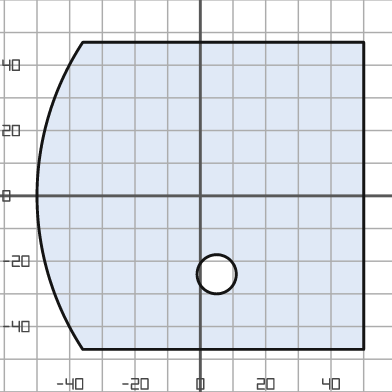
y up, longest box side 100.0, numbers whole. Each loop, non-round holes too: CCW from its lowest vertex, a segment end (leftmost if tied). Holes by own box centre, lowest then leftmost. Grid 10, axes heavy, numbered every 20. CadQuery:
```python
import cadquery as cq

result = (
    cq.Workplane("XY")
    .moveTo(-36.0, -47.0)
    .lineTo(50.0, -47.0)
    .lineTo(50.0, 47.0)
    .lineTo(-36.0, 47.0)
    .threePointArc((-50.0, 0.0), (-36.0, -47.0))
    .close()
    .moveTo(5.0, -24.0)
    .circle(6.0)
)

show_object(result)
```